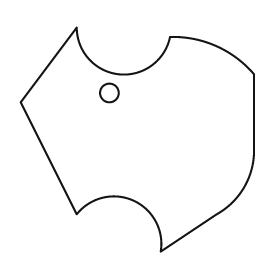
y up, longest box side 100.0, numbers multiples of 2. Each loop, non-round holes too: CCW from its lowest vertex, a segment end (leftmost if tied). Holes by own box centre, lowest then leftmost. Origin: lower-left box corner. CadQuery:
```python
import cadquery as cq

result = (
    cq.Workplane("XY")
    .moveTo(60.0, 0.0)
    .lineTo(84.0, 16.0)
    .threePointArc((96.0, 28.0), (100.0, 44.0))
    .lineTo(100.0, 76.0)
    .threePointArc((84.0, 88.0), (64.0, 92.0))
    .threePointArc((42.0, 76.0), (24.0, 96.0))
    .lineTo(0.0, 64.0)
    .lineTo(24.0, 16.0)
    .threePointArc((48.0, 22.0), (60.0, 0.0))
    .close()
    .moveTo(38.0, 68.0)
    .circle(4.0)
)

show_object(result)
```